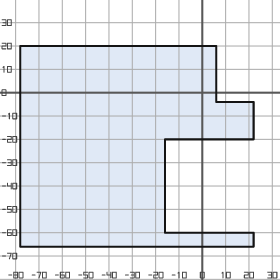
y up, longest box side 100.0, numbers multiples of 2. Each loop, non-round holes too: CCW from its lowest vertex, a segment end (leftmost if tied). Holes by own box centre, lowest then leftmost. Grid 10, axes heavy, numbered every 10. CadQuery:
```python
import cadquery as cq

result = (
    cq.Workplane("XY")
    .moveTo(-78.0, -66.0)
    .lineTo(22.0, -66.0)
    .lineTo(22.0, -60.0)
    .lineTo(-16.0, -60.0)
    .lineTo(-16.0, -20.0)
    .lineTo(22.0, -20.0)
    .lineTo(22.0, -4.0)
    .lineTo(6.0, -4.0)
    .lineTo(6.0, 20.0)
    .lineTo(-78.0, 20.0)
    .close()
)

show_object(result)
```